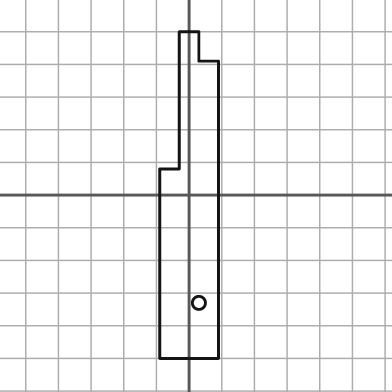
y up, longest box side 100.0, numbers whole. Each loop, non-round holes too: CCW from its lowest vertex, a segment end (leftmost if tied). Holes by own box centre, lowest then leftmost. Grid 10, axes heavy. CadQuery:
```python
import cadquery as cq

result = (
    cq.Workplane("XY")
    .moveTo(-9.0, -50.0)
    .lineTo(9.0, -50.0)
    .lineTo(9.0, 41.0)
    .lineTo(3.0, 41.0)
    .lineTo(3.0, 50.0)
    .lineTo(-3.0, 50.0)
    .lineTo(-3.0, 8.0)
    .lineTo(-9.0, 8.0)
    .close()
    .moveTo(3.0, -33.0)
    .circle(2.0)
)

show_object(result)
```